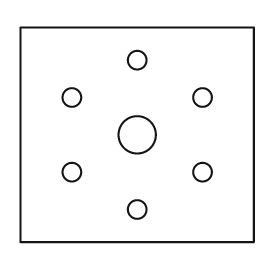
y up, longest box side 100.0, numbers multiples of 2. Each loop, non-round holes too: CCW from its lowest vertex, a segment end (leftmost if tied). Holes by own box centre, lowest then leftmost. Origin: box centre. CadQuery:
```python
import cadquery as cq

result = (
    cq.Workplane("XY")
    .moveTo(-50.0, -46.0)
    .lineTo(50.0, -46.0)
    .lineTo(50.0, 46.0)
    .lineTo(-50.0, 46.0)
    .close()
    .moveTo(0.0, -32.0)
    .circle(4.0)
    .moveTo(-28.0, -16.0)
    .circle(4.0)
    .moveTo(28.0, -16.0)
    .circle(4.0)
    .moveTo(0.0, 0.0)
    .circle(8.0)
    .moveTo(-28.0, 16.0)
    .circle(4.0)
    .moveTo(28.0, 16.0)
    .circle(4.0)
    .moveTo(0.0, 32.0)
    .circle(4.0)
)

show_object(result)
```